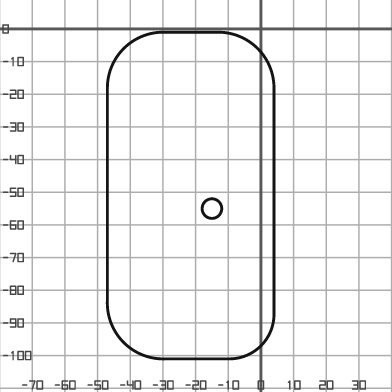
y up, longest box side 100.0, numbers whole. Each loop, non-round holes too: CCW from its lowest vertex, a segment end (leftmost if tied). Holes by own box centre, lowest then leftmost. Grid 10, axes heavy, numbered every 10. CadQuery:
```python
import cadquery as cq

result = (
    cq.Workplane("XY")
    .moveTo(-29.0, -101.0)
    .lineTo(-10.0, -101.0)
    .threePointArc((0.0, -97.0), (4.0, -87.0))
    .lineTo(4.0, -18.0)
    .threePointArc((-1.0, -6.0), (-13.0, -1.0))
    .lineTo(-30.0, -1.0)
    .threePointArc((-42.0, -6.0), (-47.0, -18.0))
    .lineTo(-47.0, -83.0)
    .threePointArc((-42.0, -96.0), (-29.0, -101.0))
    .close()
    .moveTo(-15.0, -55.0)
    .circle(3.0)
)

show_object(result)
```